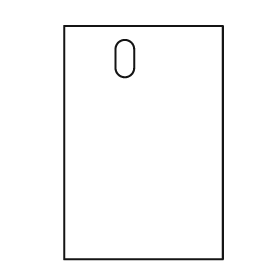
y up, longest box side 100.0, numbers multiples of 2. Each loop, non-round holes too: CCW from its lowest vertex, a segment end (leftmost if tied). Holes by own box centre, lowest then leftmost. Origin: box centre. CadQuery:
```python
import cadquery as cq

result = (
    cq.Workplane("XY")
    .moveTo(-34.0, -50.0)
    .lineTo(34.0, -50.0)
    .lineTo(34.0, 50.0)
    .lineTo(-34.0, 50.0)
    .close()
    .moveTo(-12.0, 32.0)
    .threePointArc((-8.0, 28.0), (-4.0, 32.0))
    .lineTo(-4.0, 40.0)
    .threePointArc((-8.0, 44.0), (-12.0, 40.0))
    .close()
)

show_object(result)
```